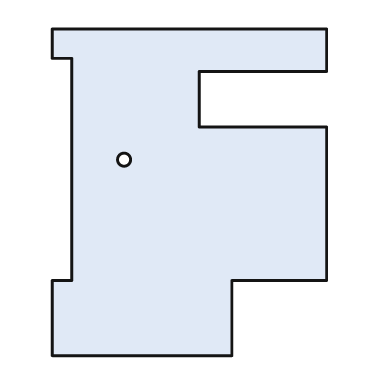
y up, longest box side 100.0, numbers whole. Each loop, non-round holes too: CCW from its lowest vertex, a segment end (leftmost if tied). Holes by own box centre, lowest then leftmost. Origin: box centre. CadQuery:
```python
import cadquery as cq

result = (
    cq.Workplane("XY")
    .moveTo(-42.0, -50.0)
    .lineTo(13.0, -50.0)
    .lineTo(13.0, -27.0)
    .lineTo(42.0, -27.0)
    .lineTo(42.0, 20.0)
    .lineTo(3.0, 20.0)
    .lineTo(3.0, 37.0)
    .lineTo(42.0, 37.0)
    .lineTo(42.0, 50.0)
    .lineTo(-42.0, 50.0)
    .lineTo(-42.0, 41.0)
    .lineTo(-36.0, 41.0)
    .lineTo(-36.0, -27.0)
    .lineTo(-42.0, -27.0)
    .close()
    .moveTo(-20.0, 10.0)
    .circle(2.0)
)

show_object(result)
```